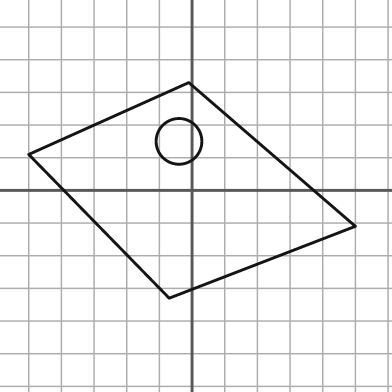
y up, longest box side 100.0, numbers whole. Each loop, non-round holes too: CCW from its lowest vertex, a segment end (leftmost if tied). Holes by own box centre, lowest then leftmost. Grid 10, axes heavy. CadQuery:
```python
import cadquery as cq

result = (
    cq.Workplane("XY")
    .moveTo(-7.0, -33.0)
    .lineTo(50.0, -11.0)
    .lineTo(-1.0, 33.0)
    .lineTo(-50.0, 11.0)
    .close()
    .moveTo(-4.0, 15.0)
    .circle(7.0)
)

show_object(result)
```